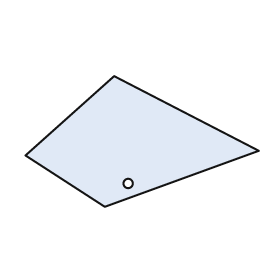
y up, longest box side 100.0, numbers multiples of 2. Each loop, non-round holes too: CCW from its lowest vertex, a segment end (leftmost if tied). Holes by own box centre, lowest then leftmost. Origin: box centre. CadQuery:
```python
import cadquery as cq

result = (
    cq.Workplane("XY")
    .moveTo(-16.0, -28.0)
    .lineTo(50.0, -4.0)
    .lineTo(-12.0, 28.0)
    .lineTo(-50.0, -6.0)
    .close()
    .moveTo(-6.0, -18.0)
    .circle(2.0)
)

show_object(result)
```